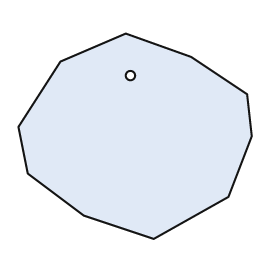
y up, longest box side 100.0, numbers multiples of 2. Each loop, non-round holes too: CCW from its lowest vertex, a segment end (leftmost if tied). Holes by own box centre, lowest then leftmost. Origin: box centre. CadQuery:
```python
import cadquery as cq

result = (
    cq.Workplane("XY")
    .moveTo(8.0, -44.0)
    .lineTo(40.0, -26.0)
    .lineTo(50.0, 0.0)
    .lineTo(48.0, 18.0)
    .lineTo(24.0, 34.0)
    .lineTo(-4.0, 44.0)
    .lineTo(-32.0, 32.0)
    .lineTo(-50.0, 4.0)
    .lineTo(-46.0, -16.0)
    .lineTo(-22.0, -34.0)
    .close()
    .moveTo(-2.0, 26.0)
    .circle(2.0)
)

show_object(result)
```